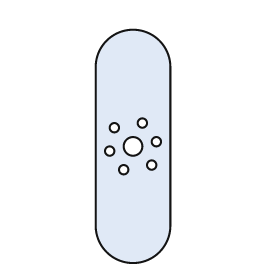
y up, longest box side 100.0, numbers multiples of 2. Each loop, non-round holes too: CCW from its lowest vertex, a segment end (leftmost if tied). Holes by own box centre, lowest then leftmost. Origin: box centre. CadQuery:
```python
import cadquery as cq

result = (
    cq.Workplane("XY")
    .moveTo(-16.0, -34.0)
    .threePointArc((0.0, -50.0), (16.0, -34.0))
    .lineTo(16.0, 34.0)
    .threePointArc((0.0, 50.0), (-16.0, 34.0))
    .close()
    .moveTo(-4.0, -10.0)
    .circle(2.0)
    .moveTo(8.0, -8.0)
    .circle(2.0)
    .moveTo(-10.0, -2.0)
    .circle(2.0)
    .moveTo(0.0, 0.0)
    .circle(4.0)
    .moveTo(10.0, 2.0)
    .circle(2.0)
    .moveTo(-8.0, 8.0)
    .circle(2.0)
    .moveTo(4.0, 10.0)
    .circle(2.0)
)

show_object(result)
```